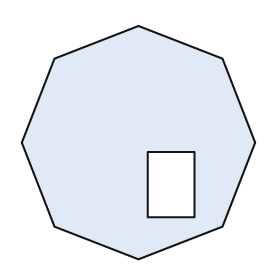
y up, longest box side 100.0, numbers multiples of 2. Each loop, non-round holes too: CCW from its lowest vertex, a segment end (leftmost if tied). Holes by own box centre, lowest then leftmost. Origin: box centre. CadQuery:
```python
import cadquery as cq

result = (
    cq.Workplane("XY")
    .moveTo(0.0, -50.0)
    .lineTo(36.0, -36.0)
    .lineTo(50.0, 0.0)
    .lineTo(36.0, 36.0)
    .lineTo(0.0, 50.0)
    .lineTo(-36.0, 36.0)
    .lineTo(-50.0, 0.0)
    .lineTo(-36.0, -36.0)
    .close()
    .moveTo(4.0, -32.0)
    .lineTo(24.0, -32.0)
    .lineTo(24.0, -4.0)
    .lineTo(4.0, -4.0)
    .close()
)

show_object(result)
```